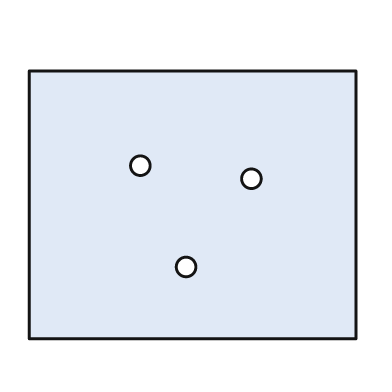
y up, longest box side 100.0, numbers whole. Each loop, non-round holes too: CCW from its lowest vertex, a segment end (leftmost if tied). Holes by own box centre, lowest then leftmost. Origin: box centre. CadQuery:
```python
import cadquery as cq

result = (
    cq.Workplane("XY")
    .moveTo(-50.0, -41.0)
    .lineTo(50.0, -41.0)
    .lineTo(50.0, 41.0)
    .lineTo(-50.0, 41.0)
    .close()
    .moveTo(-2.0, -19.0)
    .circle(3.0)
    .moveTo(18.0, 8.0)
    .circle(3.0)
    .moveTo(-16.0, 12.0)
    .circle(3.0)
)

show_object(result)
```